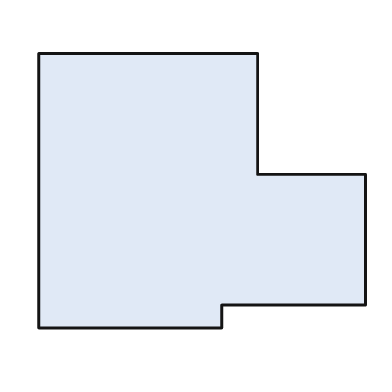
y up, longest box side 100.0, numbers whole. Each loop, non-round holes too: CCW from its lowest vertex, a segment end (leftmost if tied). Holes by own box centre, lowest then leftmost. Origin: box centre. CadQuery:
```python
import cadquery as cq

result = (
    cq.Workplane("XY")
    .moveTo(-50.0, -42.0)
    .lineTo(6.0, -42.0)
    .lineTo(6.0, -35.0)
    .lineTo(50.0, -35.0)
    .lineTo(50.0, 5.0)
    .lineTo(17.0, 5.0)
    .lineTo(17.0, 42.0)
    .lineTo(-50.0, 42.0)
    .close()
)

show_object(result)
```